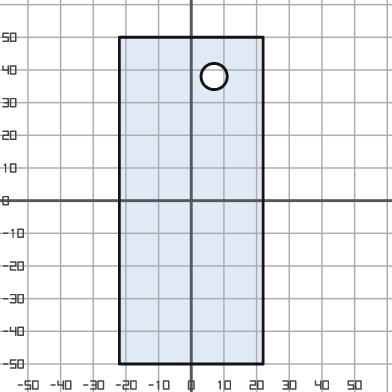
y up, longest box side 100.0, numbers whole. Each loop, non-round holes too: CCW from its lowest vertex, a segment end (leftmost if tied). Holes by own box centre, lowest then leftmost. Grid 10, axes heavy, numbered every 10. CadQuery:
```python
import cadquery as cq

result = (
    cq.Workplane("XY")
    .moveTo(-22.0, -50.0)
    .lineTo(22.0, -50.0)
    .lineTo(22.0, 50.0)
    .lineTo(-22.0, 50.0)
    .close()
    .moveTo(7.0, 38.0)
    .circle(4.0)
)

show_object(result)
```